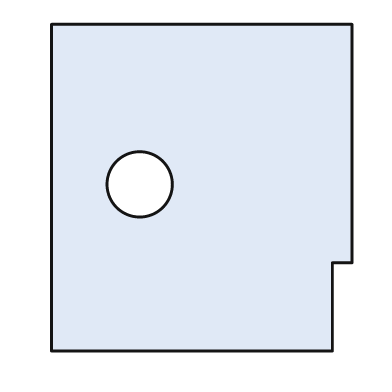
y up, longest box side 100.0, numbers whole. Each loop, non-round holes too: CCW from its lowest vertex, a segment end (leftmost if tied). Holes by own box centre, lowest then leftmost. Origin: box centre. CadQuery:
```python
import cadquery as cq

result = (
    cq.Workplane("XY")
    .moveTo(-46.0, -50.0)
    .lineTo(40.0, -50.0)
    .lineTo(40.0, -23.0)
    .lineTo(46.0, -23.0)
    .lineTo(46.0, 50.0)
    .lineTo(-46.0, 50.0)
    .close()
    .moveTo(-19.0, 1.0)
    .circle(10.0)
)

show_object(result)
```